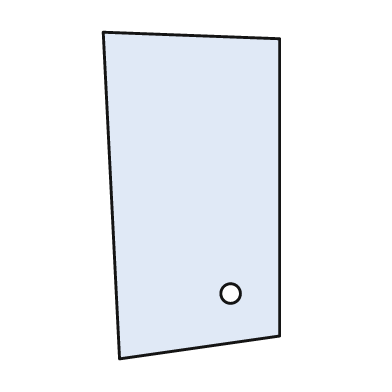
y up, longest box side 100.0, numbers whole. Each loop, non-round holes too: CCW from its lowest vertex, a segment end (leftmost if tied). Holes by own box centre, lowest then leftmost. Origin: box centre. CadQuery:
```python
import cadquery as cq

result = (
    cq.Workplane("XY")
    .moveTo(-22.0, -50.0)
    .lineTo(27.0, -43.0)
    .lineTo(27.0, 48.0)
    .lineTo(-27.0, 50.0)
    .close()
    .moveTo(12.0, -30.0)
    .circle(3.0)
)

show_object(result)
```